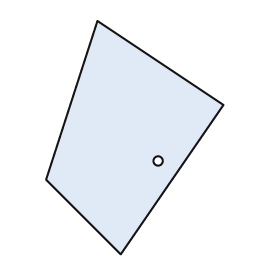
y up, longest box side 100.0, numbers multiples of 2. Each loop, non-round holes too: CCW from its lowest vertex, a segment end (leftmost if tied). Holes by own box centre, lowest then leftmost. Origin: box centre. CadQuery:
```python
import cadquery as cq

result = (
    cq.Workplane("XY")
    .moveTo(-6.0, -50.0)
    .lineTo(38.0, 14.0)
    .lineTo(-16.0, 50.0)
    .lineTo(-38.0, -18.0)
    .close()
    .moveTo(10.0, -10.0)
    .circle(2.0)
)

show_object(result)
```